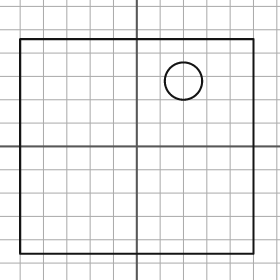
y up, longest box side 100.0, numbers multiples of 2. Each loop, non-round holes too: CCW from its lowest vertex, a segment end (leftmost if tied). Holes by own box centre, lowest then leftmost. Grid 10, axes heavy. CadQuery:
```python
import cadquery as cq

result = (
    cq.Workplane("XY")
    .moveTo(-50.0, -46.0)
    .lineTo(50.0, -46.0)
    .lineTo(50.0, 46.0)
    .lineTo(-50.0, 46.0)
    .close()
    .moveTo(20.0, 28.0)
    .circle(8.0)
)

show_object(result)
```